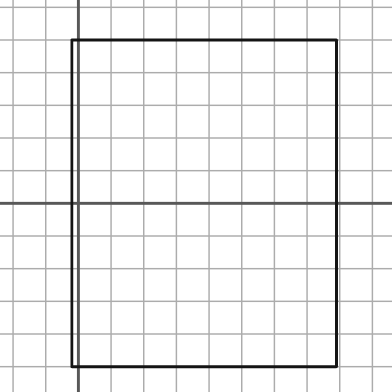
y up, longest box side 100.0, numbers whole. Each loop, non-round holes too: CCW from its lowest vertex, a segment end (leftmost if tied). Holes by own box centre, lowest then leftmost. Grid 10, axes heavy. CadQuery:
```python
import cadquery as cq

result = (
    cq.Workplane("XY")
    .moveTo(-2.0, -50.0)
    .lineTo(79.0, -50.0)
    .lineTo(79.0, 50.0)
    .lineTo(-2.0, 50.0)
    .close()
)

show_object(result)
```